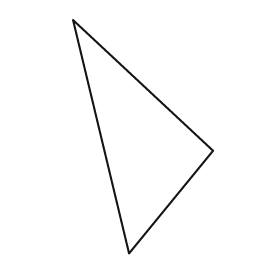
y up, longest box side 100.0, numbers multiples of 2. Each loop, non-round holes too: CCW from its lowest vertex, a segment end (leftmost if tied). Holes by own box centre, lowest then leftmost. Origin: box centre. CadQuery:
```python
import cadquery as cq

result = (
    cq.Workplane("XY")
    .moveTo(-6.0, -50.0)
    .lineTo(30.0, -6.0)
    .lineTo(-30.0, 50.0)
    .close()
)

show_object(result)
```